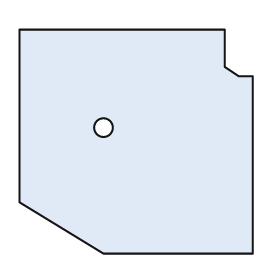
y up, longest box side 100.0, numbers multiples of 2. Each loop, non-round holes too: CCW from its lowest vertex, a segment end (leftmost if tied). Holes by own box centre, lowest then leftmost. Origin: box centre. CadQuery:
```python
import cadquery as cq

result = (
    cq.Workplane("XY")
    .moveTo(-14.0, -48.0)
    .lineTo(50.0, -48.0)
    .lineTo(50.0, 28.0)
    .lineTo(44.0, 28.0)
    .lineTo(38.0, 32.0)
    .lineTo(38.0, 48.0)
    .lineTo(-50.0, 48.0)
    .lineTo(-50.0, -26.0)
    .close()
    .moveTo(-14.0, 6.0)
    .circle(4.0)
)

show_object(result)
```